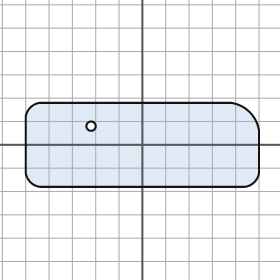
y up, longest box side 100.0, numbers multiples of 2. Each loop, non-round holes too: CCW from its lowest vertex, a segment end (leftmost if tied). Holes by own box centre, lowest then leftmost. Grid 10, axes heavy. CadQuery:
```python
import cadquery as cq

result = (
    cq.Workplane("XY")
    .moveTo(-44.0, -18.0)
    .lineTo(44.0, -18.0)
    .threePointArc((48.0, -16.0), (50.0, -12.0))
    .lineTo(50.0, 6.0)
    .threePointArc((46.0, 14.0), (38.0, 18.0))
    .lineTo(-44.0, 18.0)
    .threePointArc((-48.0, 16.0), (-50.0, 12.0))
    .lineTo(-50.0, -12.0)
    .threePointArc((-48.0, -16.0), (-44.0, -18.0))
    .close()
    .moveTo(-22.0, 8.0)
    .circle(2.0)
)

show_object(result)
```